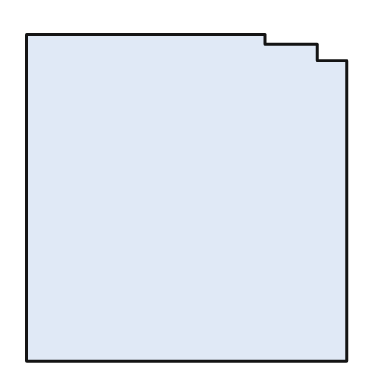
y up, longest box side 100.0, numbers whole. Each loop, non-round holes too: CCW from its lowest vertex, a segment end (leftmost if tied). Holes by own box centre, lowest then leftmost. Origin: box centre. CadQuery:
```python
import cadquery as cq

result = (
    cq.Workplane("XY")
    .moveTo(-49.0, -50.0)
    .lineTo(49.0, -50.0)
    .lineTo(49.0, 42.0)
    .lineTo(40.0, 42.0)
    .lineTo(40.0, 47.0)
    .lineTo(24.0, 47.0)
    .lineTo(24.0, 50.0)
    .lineTo(-49.0, 50.0)
    .close()
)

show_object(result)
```